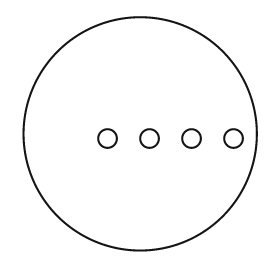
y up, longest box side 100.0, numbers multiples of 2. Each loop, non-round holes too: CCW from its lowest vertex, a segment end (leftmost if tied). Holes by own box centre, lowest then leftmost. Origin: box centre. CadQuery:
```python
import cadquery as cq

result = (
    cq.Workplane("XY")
    .moveTo(0.0, 0.0)
    .circle(50.0)
    .moveTo(-14.0, -2.0)
    .circle(4.0)
    .moveTo(4.0, -2.0)
    .circle(4.0)
    .moveTo(22.0, -2.0)
    .circle(4.0)
    .moveTo(40.0, -2.0)
    .circle(4.0)
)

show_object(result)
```